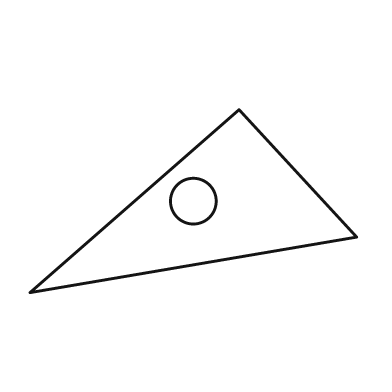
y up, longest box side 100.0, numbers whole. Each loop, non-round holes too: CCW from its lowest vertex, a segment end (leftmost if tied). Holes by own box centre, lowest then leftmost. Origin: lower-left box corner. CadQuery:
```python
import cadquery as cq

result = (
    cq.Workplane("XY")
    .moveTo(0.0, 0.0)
    .lineTo(100.0, 17.0)
    .lineTo(64.0, 56.0)
    .close()
    .moveTo(50.0, 28.0)
    .circle(7.0)
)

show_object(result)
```